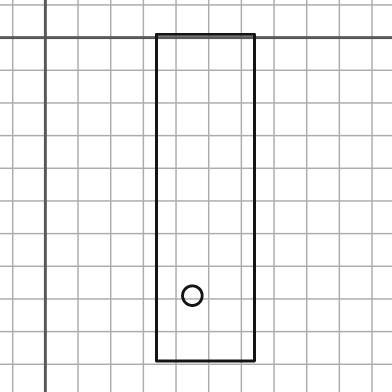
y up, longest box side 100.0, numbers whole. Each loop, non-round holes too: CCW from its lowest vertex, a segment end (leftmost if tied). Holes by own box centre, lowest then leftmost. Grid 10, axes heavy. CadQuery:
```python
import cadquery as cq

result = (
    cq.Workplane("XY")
    .moveTo(34.0, -99.0)
    .lineTo(64.0, -99.0)
    .lineTo(64.0, 1.0)
    .lineTo(34.0, 1.0)
    .close()
    .moveTo(45.0, -79.0)
    .circle(3.0)
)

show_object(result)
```